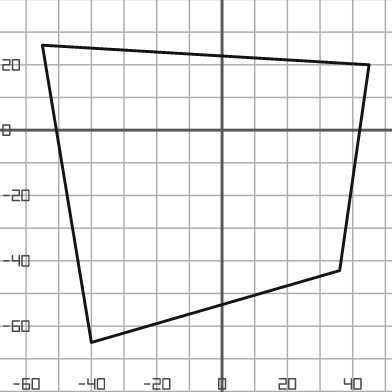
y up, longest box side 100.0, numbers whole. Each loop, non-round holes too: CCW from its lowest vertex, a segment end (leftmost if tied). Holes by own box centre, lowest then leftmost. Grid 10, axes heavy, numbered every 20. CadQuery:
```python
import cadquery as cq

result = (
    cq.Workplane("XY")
    .moveTo(-40.0, -65.0)
    .lineTo(36.0, -43.0)
    .lineTo(45.0, 20.0)
    .lineTo(-55.0, 26.0)
    .close()
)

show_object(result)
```